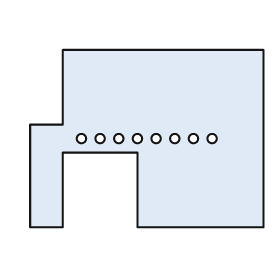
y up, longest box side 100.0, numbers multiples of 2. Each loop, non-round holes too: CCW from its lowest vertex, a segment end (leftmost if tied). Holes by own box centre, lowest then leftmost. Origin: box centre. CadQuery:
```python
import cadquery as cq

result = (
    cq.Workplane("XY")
    .moveTo(-50.0, -38.0)
    .lineTo(-36.0, -38.0)
    .lineTo(-36.0, -6.0)
    .lineTo(-4.0, -6.0)
    .lineTo(-4.0, -38.0)
    .lineTo(50.0, -38.0)
    .lineTo(50.0, 38.0)
    .lineTo(-36.0, 38.0)
    .lineTo(-36.0, 6.0)
    .lineTo(-50.0, 6.0)
    .close()
    .moveTo(-28.0, 0.0)
    .circle(2.0)
    .moveTo(-20.0, 0.0)
    .circle(2.0)
    .moveTo(-12.0, 0.0)
    .circle(2.0)
    .moveTo(-4.0, 0.0)
    .circle(2.0)
    .moveTo(4.0, 0.0)
    .circle(2.0)
    .moveTo(12.0, 0.0)
    .circle(2.0)
    .moveTo(20.0, 0.0)
    .circle(2.0)
    .moveTo(28.0, 0.0)
    .circle(2.0)
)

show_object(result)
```